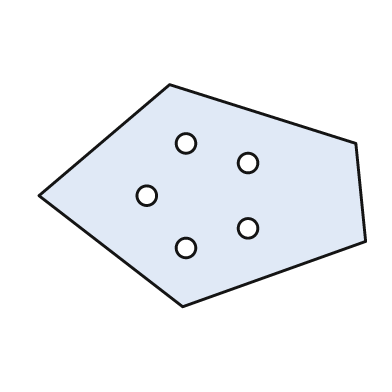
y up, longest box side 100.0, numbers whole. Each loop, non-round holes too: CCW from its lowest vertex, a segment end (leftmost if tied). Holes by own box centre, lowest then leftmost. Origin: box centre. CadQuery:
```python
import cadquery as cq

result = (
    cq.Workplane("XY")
    .moveTo(-6.0, -34.0)
    .lineTo(50.0, -14.0)
    .lineTo(47.0, 16.0)
    .lineTo(-10.0, 34.0)
    .lineTo(-50.0, 0.0)
    .close()
    .moveTo(-5.0, -16.0)
    .circle(3.0)
    .moveTo(14.0, -10.0)
    .circle(3.0)
    .moveTo(-17.0, 0.0)
    .circle(3.0)
    .moveTo(14.0, 10.0)
    .circle(3.0)
    .moveTo(-5.0, 16.0)
    .circle(3.0)
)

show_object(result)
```